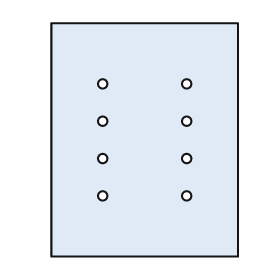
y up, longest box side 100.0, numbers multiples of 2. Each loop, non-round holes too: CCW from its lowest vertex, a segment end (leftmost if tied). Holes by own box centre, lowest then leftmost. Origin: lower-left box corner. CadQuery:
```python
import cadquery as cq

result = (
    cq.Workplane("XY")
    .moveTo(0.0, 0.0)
    .lineTo(80.0, 0.0)
    .lineTo(80.0, 100.0)
    .lineTo(0.0, 100.0)
    .close()
    .moveTo(22.0, 26.0)
    .circle(2.0)
    .moveTo(58.0, 26.0)
    .circle(2.0)
    .moveTo(22.0, 42.0)
    .circle(2.0)
    .moveTo(58.0, 42.0)
    .circle(2.0)
    .moveTo(22.0, 58.0)
    .circle(2.0)
    .moveTo(58.0, 58.0)
    .circle(2.0)
    .moveTo(22.0, 74.0)
    .circle(2.0)
    .moveTo(58.0, 74.0)
    .circle(2.0)
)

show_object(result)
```